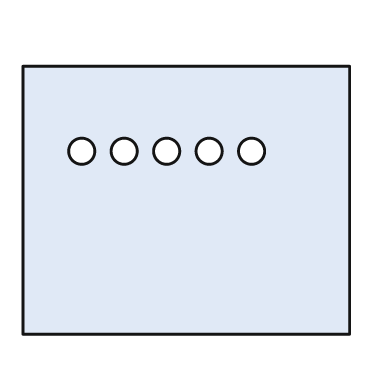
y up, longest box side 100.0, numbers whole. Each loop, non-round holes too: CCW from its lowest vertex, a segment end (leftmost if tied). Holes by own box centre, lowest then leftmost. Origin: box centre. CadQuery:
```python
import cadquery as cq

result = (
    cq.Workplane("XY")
    .moveTo(-50.0, -41.0)
    .lineTo(50.0, -41.0)
    .lineTo(50.0, 41.0)
    .lineTo(-50.0, 41.0)
    .close()
    .moveTo(-32.0, 15.0)
    .circle(4.0)
    .moveTo(-19.0, 15.0)
    .circle(4.0)
    .moveTo(-6.0, 15.0)
    .circle(4.0)
    .moveTo(7.0, 15.0)
    .circle(4.0)
    .moveTo(20.0, 15.0)
    .circle(4.0)
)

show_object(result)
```